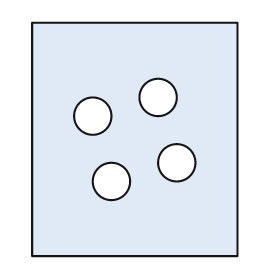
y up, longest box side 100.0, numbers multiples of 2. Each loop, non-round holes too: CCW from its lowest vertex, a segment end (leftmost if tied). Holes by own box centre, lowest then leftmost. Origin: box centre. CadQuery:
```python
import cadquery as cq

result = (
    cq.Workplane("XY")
    .moveTo(-44.0, -50.0)
    .lineTo(44.0, -50.0)
    .lineTo(44.0, 50.0)
    .lineTo(-44.0, 50.0)
    .close()
    .moveTo(-10.0, -18.0)
    .circle(8.0)
    .moveTo(18.0, -10.0)
    .circle(8.0)
    .moveTo(-18.0, 10.0)
    .circle(8.0)
    .moveTo(10.0, 18.0)
    .circle(8.0)
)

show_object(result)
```